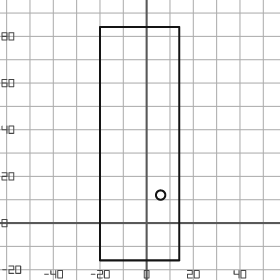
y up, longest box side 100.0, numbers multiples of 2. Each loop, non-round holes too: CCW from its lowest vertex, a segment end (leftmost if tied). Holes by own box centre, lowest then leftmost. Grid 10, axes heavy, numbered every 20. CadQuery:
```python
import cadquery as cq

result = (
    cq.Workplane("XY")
    .moveTo(-20.0, -16.0)
    .lineTo(14.0, -16.0)
    .lineTo(14.0, 84.0)
    .lineTo(-20.0, 84.0)
    .close()
    .moveTo(6.0, 12.0)
    .circle(2.0)
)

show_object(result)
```